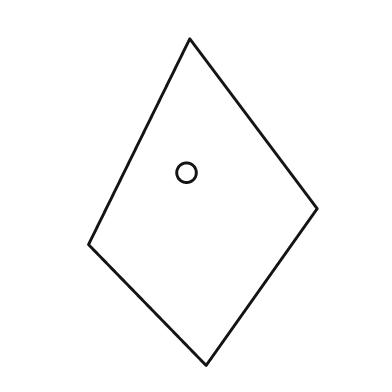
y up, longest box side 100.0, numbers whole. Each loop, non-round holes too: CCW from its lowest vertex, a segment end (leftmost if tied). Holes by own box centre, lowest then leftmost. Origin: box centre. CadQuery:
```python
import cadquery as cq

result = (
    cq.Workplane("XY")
    .moveTo(1.0, -50.0)
    .lineTo(35.0, -2.0)
    .lineTo(-4.0, 50.0)
    .lineTo(-35.0, -13.0)
    .close()
    .moveTo(-5.0, 9.0)
    .circle(3.0)
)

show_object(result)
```